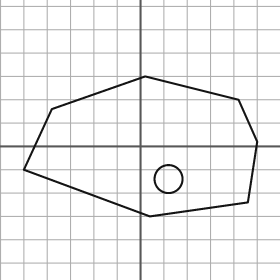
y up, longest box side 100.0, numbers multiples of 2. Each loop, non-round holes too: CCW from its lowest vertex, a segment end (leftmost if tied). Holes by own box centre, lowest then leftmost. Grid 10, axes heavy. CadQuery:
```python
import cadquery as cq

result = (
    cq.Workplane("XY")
    .moveTo(4.0, -30.0)
    .lineTo(46.0, -24.0)
    .lineTo(50.0, 2.0)
    .lineTo(42.0, 20.0)
    .lineTo(2.0, 30.0)
    .lineTo(-38.0, 16.0)
    .lineTo(-50.0, -10.0)
    .close()
    .moveTo(12.0, -14.0)
    .circle(6.0)
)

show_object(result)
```